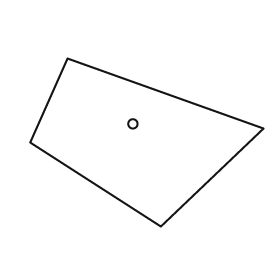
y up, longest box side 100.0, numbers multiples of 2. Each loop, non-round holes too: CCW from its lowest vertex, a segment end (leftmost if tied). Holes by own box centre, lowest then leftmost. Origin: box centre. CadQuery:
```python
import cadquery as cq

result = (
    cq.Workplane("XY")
    .moveTo(6.0, -36.0)
    .lineTo(50.0, 6.0)
    .lineTo(-34.0, 36.0)
    .lineTo(-50.0, 0.0)
    .close()
    .moveTo(-6.0, 8.0)
    .circle(2.0)
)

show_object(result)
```